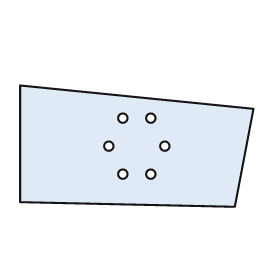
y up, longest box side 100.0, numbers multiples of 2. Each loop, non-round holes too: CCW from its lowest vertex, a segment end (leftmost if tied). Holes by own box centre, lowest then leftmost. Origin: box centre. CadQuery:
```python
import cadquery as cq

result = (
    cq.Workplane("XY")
    .moveTo(42.0, -26.0)
    .lineTo(50.0, 16.0)
    .lineTo(-50.0, 26.0)
    .lineTo(-50.0, -24.0)
    .close()
    .moveTo(-6.0, -12.0)
    .circle(2.0)
    .moveTo(6.0, -12.0)
    .circle(2.0)
    .moveTo(-12.0, 0.0)
    .circle(2.0)
    .moveTo(12.0, 0.0)
    .circle(2.0)
    .moveTo(-6.0, 12.0)
    .circle(2.0)
    .moveTo(6.0, 12.0)
    .circle(2.0)
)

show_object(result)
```